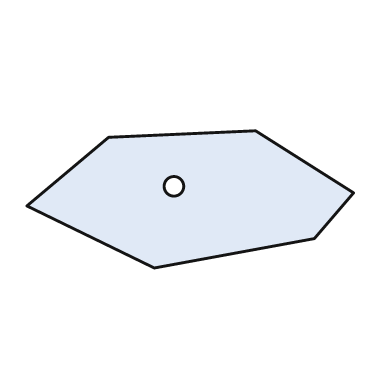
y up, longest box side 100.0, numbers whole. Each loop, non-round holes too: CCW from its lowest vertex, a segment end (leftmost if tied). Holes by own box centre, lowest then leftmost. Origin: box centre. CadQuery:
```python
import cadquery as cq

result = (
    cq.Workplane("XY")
    .moveTo(-11.0, -21.0)
    .lineTo(38.0, -12.0)
    .lineTo(50.0, 2.0)
    .lineTo(20.0, 21.0)
    .lineTo(-25.0, 19.0)
    .lineTo(-50.0, -2.0)
    .close()
    .moveTo(-5.0, 4.0)
    .circle(3.0)
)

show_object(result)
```